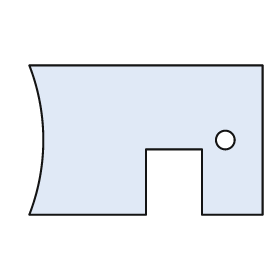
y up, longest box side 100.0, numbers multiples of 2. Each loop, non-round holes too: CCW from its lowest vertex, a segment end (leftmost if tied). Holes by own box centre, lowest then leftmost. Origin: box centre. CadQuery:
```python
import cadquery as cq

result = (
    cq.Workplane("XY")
    .moveTo(-50.0, -32.0)
    .lineTo(0.0, -32.0)
    .lineTo(0.0, -4.0)
    .lineTo(24.0, -4.0)
    .lineTo(24.0, -32.0)
    .lineTo(50.0, -32.0)
    .lineTo(50.0, 32.0)
    .lineTo(-50.0, 32.0)
    .threePointArc((-44.0, 0.0), (-50.0, -32.0))
    .close()
    .moveTo(34.0, 0.0)
    .circle(4.0)
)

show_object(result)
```